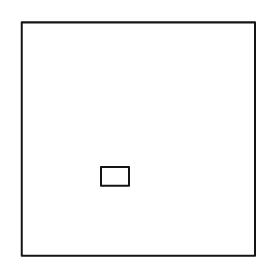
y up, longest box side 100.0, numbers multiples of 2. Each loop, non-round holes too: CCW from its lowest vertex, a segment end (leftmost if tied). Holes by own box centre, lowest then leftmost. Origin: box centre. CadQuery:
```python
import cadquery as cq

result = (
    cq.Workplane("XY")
    .moveTo(-50.0, -50.0)
    .lineTo(50.0, -50.0)
    .lineTo(50.0, 50.0)
    .lineTo(-50.0, 50.0)
    .close()
    .moveTo(-16.0, -20.0)
    .lineTo(-4.0, -20.0)
    .lineTo(-4.0, -12.0)
    .lineTo(-16.0, -12.0)
    .close()
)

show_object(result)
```